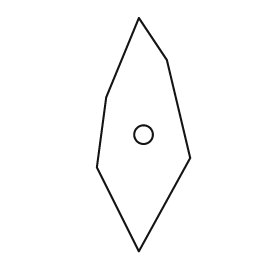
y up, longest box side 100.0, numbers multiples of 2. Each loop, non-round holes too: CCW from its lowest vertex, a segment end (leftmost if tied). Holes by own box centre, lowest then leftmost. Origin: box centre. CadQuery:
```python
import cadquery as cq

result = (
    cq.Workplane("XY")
    .moveTo(-2.0, -50.0)
    .lineTo(20.0, -10.0)
    .lineTo(10.0, 32.0)
    .lineTo(-2.0, 50.0)
    .lineTo(-16.0, 16.0)
    .lineTo(-20.0, -14.0)
    .close()
    .moveTo(0.0, 0.0)
    .circle(4.0)
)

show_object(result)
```